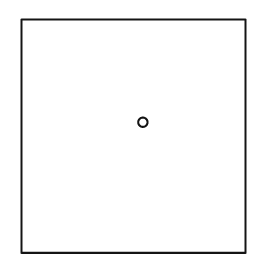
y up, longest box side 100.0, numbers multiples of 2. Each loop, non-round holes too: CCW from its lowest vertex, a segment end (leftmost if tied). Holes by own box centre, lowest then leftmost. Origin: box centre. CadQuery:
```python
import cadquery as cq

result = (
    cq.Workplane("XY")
    .moveTo(-48.0, -50.0)
    .lineTo(48.0, -50.0)
    .lineTo(48.0, 50.0)
    .lineTo(-48.0, 50.0)
    .close()
    .moveTo(4.0, 6.0)
    .circle(2.0)
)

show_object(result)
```